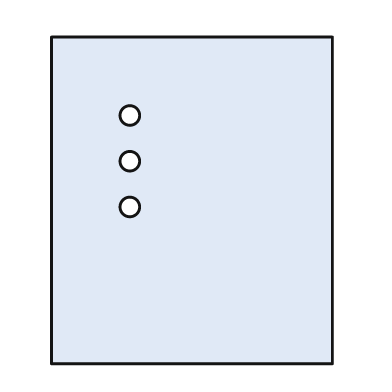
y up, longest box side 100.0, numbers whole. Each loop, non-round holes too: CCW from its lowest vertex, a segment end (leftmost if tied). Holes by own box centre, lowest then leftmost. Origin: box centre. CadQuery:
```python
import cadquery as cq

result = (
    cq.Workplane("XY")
    .moveTo(-43.0, -50.0)
    .lineTo(43.0, -50.0)
    .lineTo(43.0, 50.0)
    .lineTo(-43.0, 50.0)
    .close()
    .moveTo(-19.0, -2.0)
    .circle(3.0)
    .moveTo(-19.0, 12.0)
    .circle(3.0)
    .moveTo(-19.0, 26.0)
    .circle(3.0)
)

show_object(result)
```